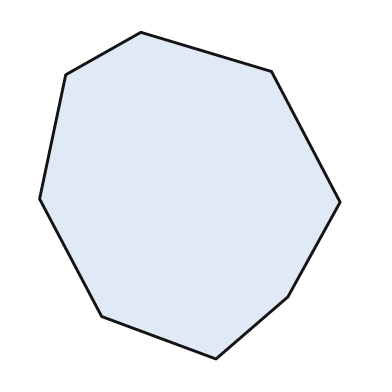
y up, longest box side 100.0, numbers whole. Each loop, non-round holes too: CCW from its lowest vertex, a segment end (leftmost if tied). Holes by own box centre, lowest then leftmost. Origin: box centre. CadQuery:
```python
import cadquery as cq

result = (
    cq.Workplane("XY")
    .moveTo(8.0, -50.0)
    .lineTo(30.0, -31.0)
    .lineTo(46.0, -2.0)
    .lineTo(25.0, 38.0)
    .lineTo(-15.0, 50.0)
    .lineTo(-38.0, 37.0)
    .lineTo(-46.0, -1.0)
    .lineTo(-27.0, -37.0)
    .close()
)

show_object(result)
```